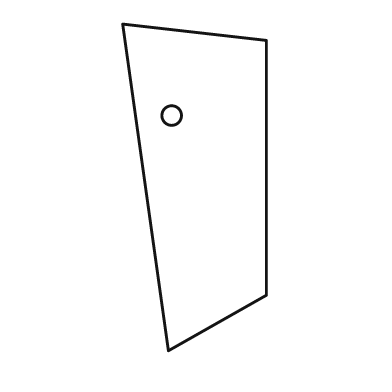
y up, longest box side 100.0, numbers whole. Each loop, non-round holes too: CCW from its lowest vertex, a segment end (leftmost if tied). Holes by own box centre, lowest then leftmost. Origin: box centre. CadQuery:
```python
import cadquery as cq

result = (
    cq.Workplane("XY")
    .moveTo(-8.0, -50.0)
    .lineTo(22.0, -33.0)
    .lineTo(22.0, 45.0)
    .lineTo(-22.0, 50.0)
    .close()
    .moveTo(-7.0, 22.0)
    .circle(3.0)
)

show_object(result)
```